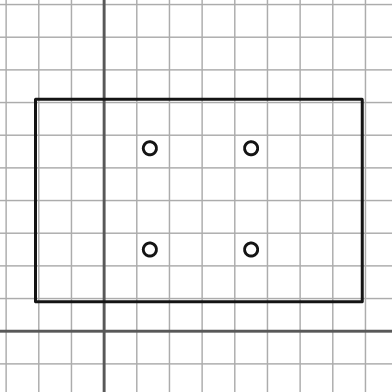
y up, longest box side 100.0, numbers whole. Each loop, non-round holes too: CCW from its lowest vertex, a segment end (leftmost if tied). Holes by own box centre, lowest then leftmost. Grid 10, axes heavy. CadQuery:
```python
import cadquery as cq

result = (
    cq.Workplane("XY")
    .moveTo(-21.0, 9.0)
    .lineTo(79.0, 9.0)
    .lineTo(79.0, 71.0)
    .lineTo(-21.0, 71.0)
    .close()
    .moveTo(14.0, 25.0)
    .circle(2.0)
    .moveTo(45.0, 25.0)
    .circle(2.0)
    .moveTo(14.0, 56.0)
    .circle(2.0)
    .moveTo(45.0, 56.0)
    .circle(2.0)
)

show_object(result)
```